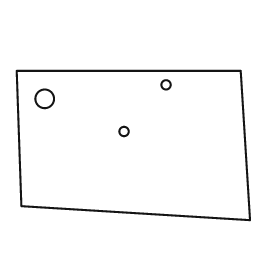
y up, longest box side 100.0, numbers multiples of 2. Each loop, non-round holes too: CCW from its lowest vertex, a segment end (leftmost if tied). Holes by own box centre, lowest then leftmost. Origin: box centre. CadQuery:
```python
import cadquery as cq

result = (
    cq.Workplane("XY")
    .moveTo(50.0, -32.0)
    .lineTo(46.0, 32.0)
    .lineTo(-50.0, 32.0)
    .lineTo(-48.0, -26.0)
    .close()
    .moveTo(-4.0, 6.0)
    .circle(2.0)
    .moveTo(-38.0, 20.0)
    .circle(4.0)
    .moveTo(14.0, 26.0)
    .circle(2.0)
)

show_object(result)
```